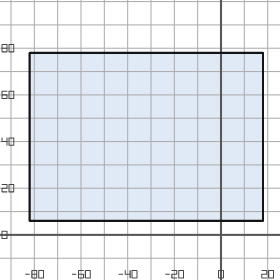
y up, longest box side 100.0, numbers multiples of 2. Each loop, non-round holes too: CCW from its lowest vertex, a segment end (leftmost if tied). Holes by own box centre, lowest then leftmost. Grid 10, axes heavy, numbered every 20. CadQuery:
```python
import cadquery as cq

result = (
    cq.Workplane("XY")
    .moveTo(-82.0, 6.0)
    .lineTo(18.0, 6.0)
    .lineTo(18.0, 78.0)
    .lineTo(-82.0, 78.0)
    .close()
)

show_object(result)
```